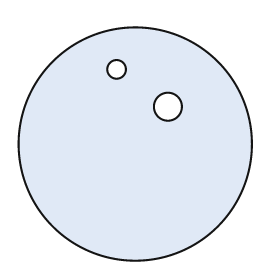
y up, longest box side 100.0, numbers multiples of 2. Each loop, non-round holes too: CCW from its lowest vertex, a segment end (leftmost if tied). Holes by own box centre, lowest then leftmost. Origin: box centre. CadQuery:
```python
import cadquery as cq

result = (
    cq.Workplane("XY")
    .moveTo(0.0, 0.0)
    .circle(50.0)
    .moveTo(14.0, 16.0)
    .circle(6.0)
    .moveTo(-8.0, 32.0)
    .circle(4.0)
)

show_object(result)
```